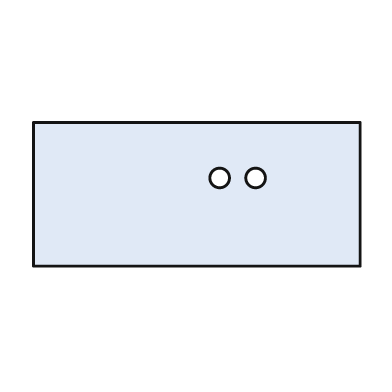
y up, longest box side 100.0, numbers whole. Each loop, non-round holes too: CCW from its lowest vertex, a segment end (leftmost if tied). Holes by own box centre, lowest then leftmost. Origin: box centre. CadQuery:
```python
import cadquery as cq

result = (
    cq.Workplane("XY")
    .moveTo(-50.0, -22.0)
    .lineTo(50.0, -22.0)
    .lineTo(50.0, 22.0)
    .lineTo(-50.0, 22.0)
    .close()
    .moveTo(7.0, 5.0)
    .circle(3.0)
    .moveTo(18.0, 5.0)
    .circle(3.0)
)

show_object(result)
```